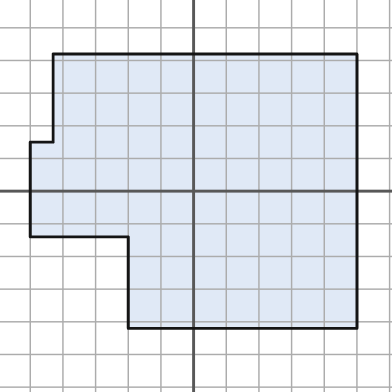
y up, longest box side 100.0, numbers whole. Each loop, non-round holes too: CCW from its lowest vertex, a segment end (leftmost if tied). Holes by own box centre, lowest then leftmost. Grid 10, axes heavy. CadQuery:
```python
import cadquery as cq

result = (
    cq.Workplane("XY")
    .moveTo(-20.0, -42.0)
    .lineTo(50.0, -42.0)
    .lineTo(50.0, 42.0)
    .lineTo(-43.0, 42.0)
    .lineTo(-43.0, 15.0)
    .lineTo(-50.0, 15.0)
    .lineTo(-50.0, -14.0)
    .lineTo(-20.0, -14.0)
    .close()
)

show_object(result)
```